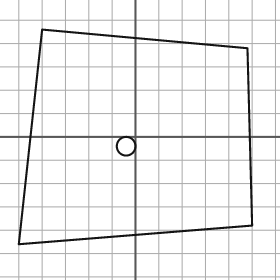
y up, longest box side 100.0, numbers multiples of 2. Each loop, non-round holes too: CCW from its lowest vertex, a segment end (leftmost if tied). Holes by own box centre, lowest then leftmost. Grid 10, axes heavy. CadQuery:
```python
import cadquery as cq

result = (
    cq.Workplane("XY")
    .moveTo(-50.0, -46.0)
    .lineTo(50.0, -38.0)
    .lineTo(48.0, 38.0)
    .lineTo(-40.0, 46.0)
    .close()
    .moveTo(-4.0, -4.0)
    .circle(4.0)
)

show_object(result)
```